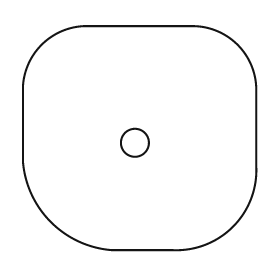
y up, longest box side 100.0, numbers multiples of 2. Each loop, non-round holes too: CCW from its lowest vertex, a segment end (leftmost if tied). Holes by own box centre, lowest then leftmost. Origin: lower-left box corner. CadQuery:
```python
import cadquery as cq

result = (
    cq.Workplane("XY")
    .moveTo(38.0, 0.0)
    .lineTo(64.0, 0.0)
    .threePointArc((90.0, 10.0), (100.0, 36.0))
    .lineTo(100.0, 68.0)
    .threePointArc((92.0, 88.0), (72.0, 96.0))
    .lineTo(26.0, 96.0)
    .threePointArc((8.0, 88.0), (0.0, 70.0))
    .lineTo(0.0, 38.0)
    .threePointArc((12.0, 12.0), (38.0, 0.0))
    .close()
    .moveTo(48.0, 46.0)
    .circle(6.0)
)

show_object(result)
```